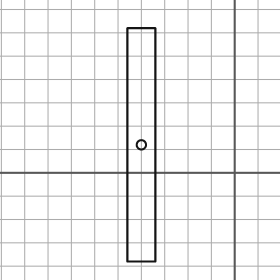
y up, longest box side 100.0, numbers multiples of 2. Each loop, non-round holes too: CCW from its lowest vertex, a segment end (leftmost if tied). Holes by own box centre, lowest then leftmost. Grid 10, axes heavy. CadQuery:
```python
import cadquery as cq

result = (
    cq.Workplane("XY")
    .moveTo(-46.0, -38.0)
    .lineTo(-34.0, -38.0)
    .lineTo(-34.0, 62.0)
    .lineTo(-46.0, 62.0)
    .close()
    .moveTo(-40.0, 12.0)
    .circle(2.0)
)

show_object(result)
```